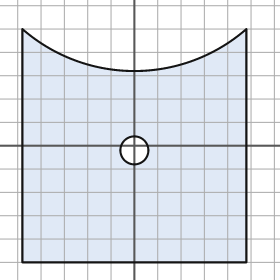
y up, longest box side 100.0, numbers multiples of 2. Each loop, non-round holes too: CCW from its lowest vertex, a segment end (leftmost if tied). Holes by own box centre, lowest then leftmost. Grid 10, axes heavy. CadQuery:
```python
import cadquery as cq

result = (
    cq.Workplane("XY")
    .moveTo(-48.0, -50.0)
    .lineTo(48.0, -50.0)
    .lineTo(48.0, 50.0)
    .threePointArc((0.0, 32.0), (-48.0, 50.0))
    .close()
    .moveTo(0.0, -2.0)
    .circle(6.0)
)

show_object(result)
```